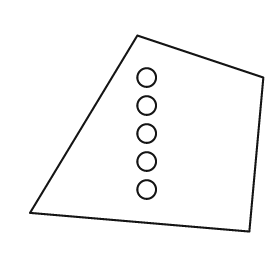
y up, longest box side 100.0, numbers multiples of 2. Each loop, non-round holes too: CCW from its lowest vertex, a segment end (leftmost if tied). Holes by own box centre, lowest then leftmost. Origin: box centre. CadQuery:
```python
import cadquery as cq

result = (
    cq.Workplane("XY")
    .moveTo(44.0, -42.0)
    .lineTo(50.0, 24.0)
    .lineTo(-4.0, 42.0)
    .lineTo(-50.0, -34.0)
    .close()
    .moveTo(0.0, -24.0)
    .circle(4.0)
    .moveTo(0.0, -12.0)
    .circle(4.0)
    .moveTo(0.0, 0.0)
    .circle(4.0)
    .moveTo(0.0, 12.0)
    .circle(4.0)
    .moveTo(0.0, 24.0)
    .circle(4.0)
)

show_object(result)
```